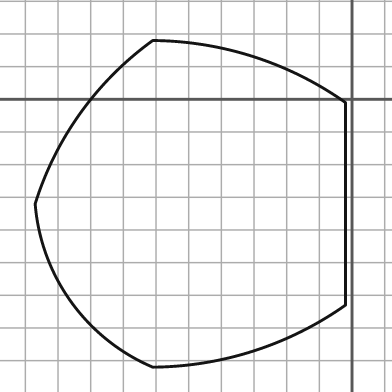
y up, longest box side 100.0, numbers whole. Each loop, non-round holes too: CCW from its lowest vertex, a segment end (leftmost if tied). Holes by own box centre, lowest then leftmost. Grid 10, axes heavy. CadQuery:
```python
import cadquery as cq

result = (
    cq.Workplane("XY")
    .moveTo(-61.0, -82.0)
    .threePointArc((-30.0, -77.0), (-2.0, -63.0))
    .lineTo(-2.0, -1.0)
    .threePointArc((-30.0, 13.0), (-61.0, 18.0))
    .threePointArc((-83.0, -4.0), (-97.0, -32.0))
    .threePointArc((-86.0, -62.0), (-61.0, -82.0))
    .close()
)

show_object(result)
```